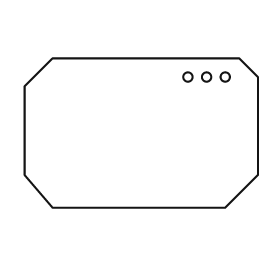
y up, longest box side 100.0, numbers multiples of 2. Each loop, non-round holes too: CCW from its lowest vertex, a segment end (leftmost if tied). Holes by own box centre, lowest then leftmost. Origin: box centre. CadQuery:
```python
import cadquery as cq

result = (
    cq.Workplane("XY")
    .moveTo(-38.0, -32.0)
    .lineTo(36.0, -32.0)
    .lineTo(50.0, -18.0)
    .lineTo(50.0, 24.0)
    .lineTo(42.0, 32.0)
    .lineTo(-38.0, 32.0)
    .lineTo(-50.0, 20.0)
    .lineTo(-50.0, -18.0)
    .close()
    .moveTo(20.0, 24.0)
    .circle(2.0)
    .moveTo(28.0, 24.0)
    .circle(2.0)
    .moveTo(36.0, 24.0)
    .circle(2.0)
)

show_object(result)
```